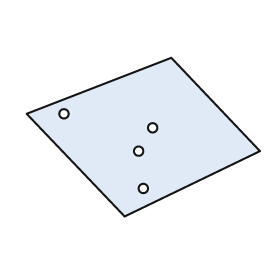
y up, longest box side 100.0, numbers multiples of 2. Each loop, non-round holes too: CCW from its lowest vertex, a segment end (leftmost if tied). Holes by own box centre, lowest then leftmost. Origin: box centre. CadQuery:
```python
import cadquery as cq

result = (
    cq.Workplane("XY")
    .moveTo(-8.0, -34.0)
    .lineTo(50.0, -6.0)
    .lineTo(12.0, 34.0)
    .lineTo(-50.0, 10.0)
    .close()
    .moveTo(0.0, -22.0)
    .circle(2.0)
    .moveTo(-2.0, -6.0)
    .circle(2.0)
    .moveTo(4.0, 4.0)
    .circle(2.0)
    .moveTo(-34.0, 10.0)
    .circle(2.0)
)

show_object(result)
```